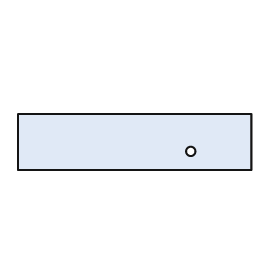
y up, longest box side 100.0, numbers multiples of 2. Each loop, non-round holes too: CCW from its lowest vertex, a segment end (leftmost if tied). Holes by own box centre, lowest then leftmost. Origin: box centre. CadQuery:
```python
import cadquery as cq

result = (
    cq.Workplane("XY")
    .moveTo(-50.0, -12.0)
    .lineTo(50.0, -12.0)
    .lineTo(50.0, 12.0)
    .lineTo(-50.0, 12.0)
    .close()
    .moveTo(24.0, -4.0)
    .circle(2.0)
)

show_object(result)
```